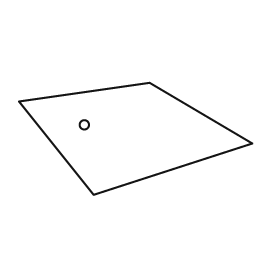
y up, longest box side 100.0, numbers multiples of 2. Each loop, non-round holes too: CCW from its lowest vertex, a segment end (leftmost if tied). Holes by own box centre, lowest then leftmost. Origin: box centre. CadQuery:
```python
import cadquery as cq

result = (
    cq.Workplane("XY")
    .moveTo(-18.0, -24.0)
    .lineTo(50.0, -2.0)
    .lineTo(6.0, 24.0)
    .lineTo(-50.0, 16.0)
    .close()
    .moveTo(-22.0, 6.0)
    .circle(2.0)
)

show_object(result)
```